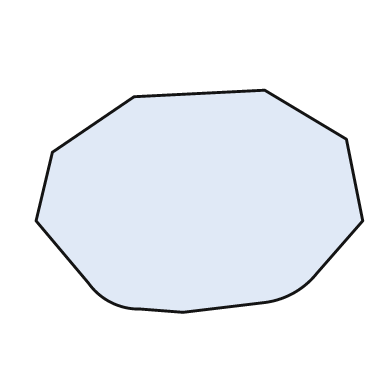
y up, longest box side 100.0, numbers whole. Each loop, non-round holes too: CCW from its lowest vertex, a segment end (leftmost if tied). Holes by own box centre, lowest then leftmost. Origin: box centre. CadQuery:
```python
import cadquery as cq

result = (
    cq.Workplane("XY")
    .moveTo(-5.0, -34.0)
    .lineTo(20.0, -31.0)
    .threePointArc((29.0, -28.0), (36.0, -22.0))
    .lineTo(50.0, -6.0)
    .lineTo(45.0, 19.0)
    .lineTo(20.0, 34.0)
    .lineTo(-20.0, 32.0)
    .lineTo(-45.0, 15.0)
    .lineTo(-50.0, -6.0)
    .lineTo(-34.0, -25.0)
    .threePointArc((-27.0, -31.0), (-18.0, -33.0))
    .close()
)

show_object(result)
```